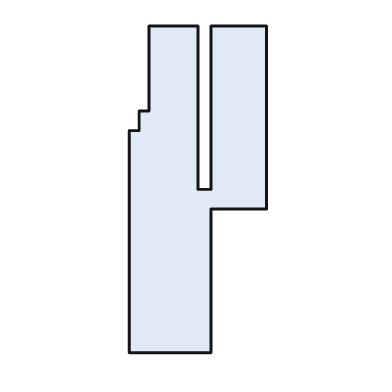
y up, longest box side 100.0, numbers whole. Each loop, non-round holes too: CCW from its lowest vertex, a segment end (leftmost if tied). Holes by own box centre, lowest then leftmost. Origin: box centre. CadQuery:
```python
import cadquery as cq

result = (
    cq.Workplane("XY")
    .moveTo(-21.0, -50.0)
    .lineTo(4.0, -50.0)
    .lineTo(4.0, -6.0)
    .lineTo(21.0, -6.0)
    .lineTo(21.0, 50.0)
    .lineTo(4.0, 50.0)
    .lineTo(4.0, 0.0)
    .lineTo(0.0, 0.0)
    .lineTo(0.0, 50.0)
    .lineTo(-15.0, 50.0)
    .lineTo(-15.0, 24.0)
    .lineTo(-18.0, 24.0)
    .lineTo(-18.0, 18.0)
    .lineTo(-21.0, 18.0)
    .close()
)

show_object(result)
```